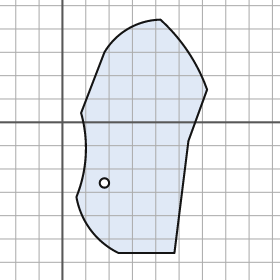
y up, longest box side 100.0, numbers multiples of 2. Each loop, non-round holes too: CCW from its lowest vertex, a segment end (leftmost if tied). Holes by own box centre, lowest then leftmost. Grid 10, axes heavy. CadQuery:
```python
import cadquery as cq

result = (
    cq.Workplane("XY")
    .moveTo(24.0, -56.0)
    .lineTo(48.0, -56.0)
    .lineTo(54.0, -8.0)
    .lineTo(62.0, 14.0)
    .threePointArc((54.0, 30.0), (42.0, 44.0))
    .threePointArc((28.0, 40.0), (18.0, 30.0))
    .lineTo(8.0, 4.0)
    .threePointArc((10.0, -14.0), (6.0, -32.0))
    .threePointArc((12.0, -46.0), (24.0, -56.0))
    .close()
    .moveTo(18.0, -26.0)
    .circle(2.0)
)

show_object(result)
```